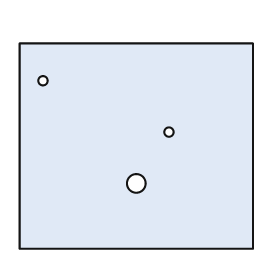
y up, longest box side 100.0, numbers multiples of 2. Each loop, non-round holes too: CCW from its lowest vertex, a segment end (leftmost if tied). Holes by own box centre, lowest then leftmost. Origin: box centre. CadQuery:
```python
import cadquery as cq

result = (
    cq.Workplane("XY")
    .moveTo(-50.0, -44.0)
    .lineTo(50.0, -44.0)
    .lineTo(50.0, 44.0)
    .lineTo(-50.0, 44.0)
    .close()
    .moveTo(0.0, -16.0)
    .circle(4.0)
    .moveTo(14.0, 6.0)
    .circle(2.0)
    .moveTo(-40.0, 28.0)
    .circle(2.0)
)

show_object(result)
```